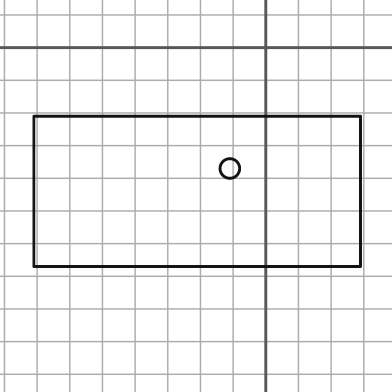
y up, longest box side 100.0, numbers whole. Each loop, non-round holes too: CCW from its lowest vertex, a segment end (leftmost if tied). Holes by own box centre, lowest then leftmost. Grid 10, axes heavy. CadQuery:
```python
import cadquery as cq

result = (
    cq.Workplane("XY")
    .moveTo(-71.0, -67.0)
    .lineTo(29.0, -67.0)
    .lineTo(29.0, -21.0)
    .lineTo(-71.0, -21.0)
    .close()
    .moveTo(-11.0, -37.0)
    .circle(3.0)
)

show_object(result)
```